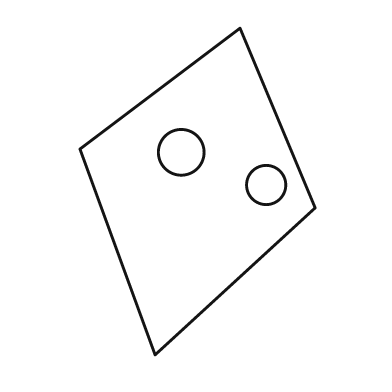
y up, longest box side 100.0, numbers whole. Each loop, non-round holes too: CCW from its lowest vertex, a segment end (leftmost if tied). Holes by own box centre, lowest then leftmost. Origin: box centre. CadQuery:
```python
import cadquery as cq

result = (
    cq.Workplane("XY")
    .moveTo(-13.0, -50.0)
    .lineTo(36.0, -5.0)
    .lineTo(13.0, 50.0)
    .lineTo(-36.0, 13.0)
    .close()
    .moveTo(21.0, 2.0)
    .circle(6.0)
    .moveTo(-5.0, 12.0)
    .circle(7.0)
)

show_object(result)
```